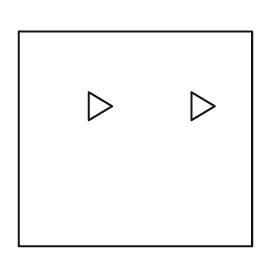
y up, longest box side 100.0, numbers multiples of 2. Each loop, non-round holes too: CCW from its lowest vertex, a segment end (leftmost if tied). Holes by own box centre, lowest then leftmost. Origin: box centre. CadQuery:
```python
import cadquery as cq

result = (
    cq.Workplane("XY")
    .moveTo(-50.0, -46.0)
    .lineTo(50.0, -46.0)
    .lineTo(50.0, 46.0)
    .lineTo(-50.0, 46.0)
    .close()
    .moveTo(-20.0, 8.0)
    .lineTo(-10.0, 14.0)
    .lineTo(-20.0, 20.0)
    .close()
    .moveTo(24.0, 8.0)
    .lineTo(34.0, 14.0)
    .lineTo(24.0, 20.0)
    .close()
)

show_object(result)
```